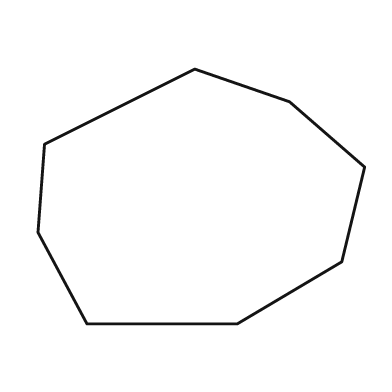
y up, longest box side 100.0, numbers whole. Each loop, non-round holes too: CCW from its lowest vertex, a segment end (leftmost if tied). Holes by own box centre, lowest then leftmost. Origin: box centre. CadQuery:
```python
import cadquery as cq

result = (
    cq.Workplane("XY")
    .moveTo(-35.0, -39.0)
    .lineTo(11.0, -39.0)
    .lineTo(43.0, -20.0)
    .lineTo(50.0, 9.0)
    .lineTo(27.0, 29.0)
    .lineTo(-2.0, 39.0)
    .lineTo(-48.0, 16.0)
    .lineTo(-50.0, -11.0)
    .close()
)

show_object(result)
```